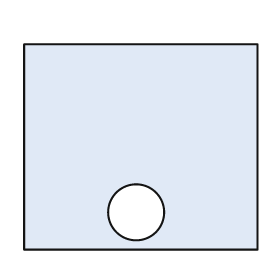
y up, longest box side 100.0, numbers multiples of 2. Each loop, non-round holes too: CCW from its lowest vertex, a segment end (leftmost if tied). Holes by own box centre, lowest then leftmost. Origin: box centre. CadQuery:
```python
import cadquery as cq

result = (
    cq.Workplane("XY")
    .moveTo(-50.0, -44.0)
    .lineTo(50.0, -44.0)
    .lineTo(50.0, 44.0)
    .lineTo(-50.0, 44.0)
    .close()
    .moveTo(-2.0, -28.0)
    .circle(12.0)
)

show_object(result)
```